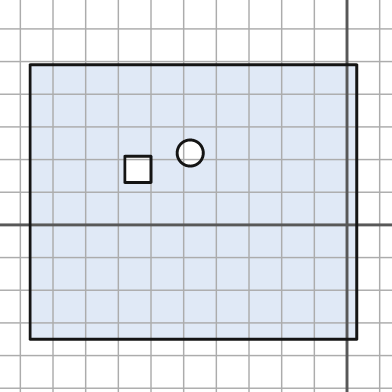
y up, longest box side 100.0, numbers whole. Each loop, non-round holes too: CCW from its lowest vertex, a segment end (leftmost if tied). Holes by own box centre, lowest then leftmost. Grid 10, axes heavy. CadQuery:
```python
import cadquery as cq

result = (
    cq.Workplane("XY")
    .moveTo(-97.0, -35.0)
    .lineTo(3.0, -35.0)
    .lineTo(3.0, 49.0)
    .lineTo(-97.0, 49.0)
    .close()
    .moveTo(-68.0, 13.0)
    .lineTo(-60.0, 13.0)
    .lineTo(-60.0, 21.0)
    .lineTo(-68.0, 21.0)
    .close()
    .moveTo(-48.0, 22.0)
    .circle(4.0)
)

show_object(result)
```